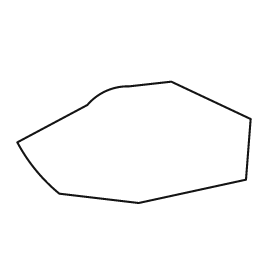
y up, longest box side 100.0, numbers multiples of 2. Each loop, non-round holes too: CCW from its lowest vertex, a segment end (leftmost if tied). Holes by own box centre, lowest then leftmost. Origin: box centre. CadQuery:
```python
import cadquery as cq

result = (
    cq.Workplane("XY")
    .moveTo(2.0, -26.0)
    .lineTo(48.0, -16.0)
    .lineTo(50.0, 10.0)
    .lineTo(16.0, 26.0)
    .lineTo(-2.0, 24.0)
    .threePointArc((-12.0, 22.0), (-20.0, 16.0))
    .lineTo(-50.0, 0.0)
    .threePointArc((-42.0, -12.0), (-32.0, -22.0))
    .close()
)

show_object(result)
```